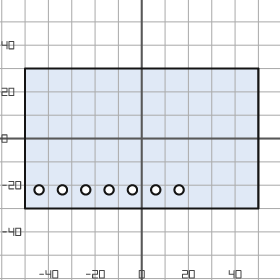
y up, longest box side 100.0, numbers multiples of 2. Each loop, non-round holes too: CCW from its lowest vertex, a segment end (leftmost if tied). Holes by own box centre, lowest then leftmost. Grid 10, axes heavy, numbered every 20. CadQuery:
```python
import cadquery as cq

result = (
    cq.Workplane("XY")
    .moveTo(-50.0, -30.0)
    .lineTo(50.0, -30.0)
    .lineTo(50.0, 30.0)
    .lineTo(-50.0, 30.0)
    .close()
    .moveTo(-44.0, -22.0)
    .circle(2.0)
    .moveTo(-34.0, -22.0)
    .circle(2.0)
    .moveTo(-24.0, -22.0)
    .circle(2.0)
    .moveTo(-14.0, -22.0)
    .circle(2.0)
    .moveTo(-4.0, -22.0)
    .circle(2.0)
    .moveTo(6.0, -22.0)
    .circle(2.0)
    .moveTo(16.0, -22.0)
    .circle(2.0)
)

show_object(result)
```